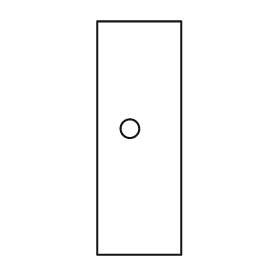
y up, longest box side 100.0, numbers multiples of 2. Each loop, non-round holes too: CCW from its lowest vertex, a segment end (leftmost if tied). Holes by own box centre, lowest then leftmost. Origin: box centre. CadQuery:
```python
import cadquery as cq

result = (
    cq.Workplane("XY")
    .moveTo(-18.0, -50.0)
    .lineTo(18.0, -50.0)
    .lineTo(18.0, 50.0)
    .lineTo(-18.0, 50.0)
    .close()
    .moveTo(-4.0, 4.0)
    .circle(4.0)
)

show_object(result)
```